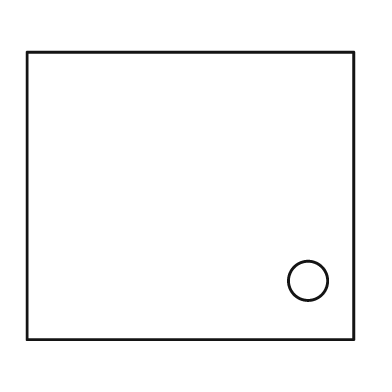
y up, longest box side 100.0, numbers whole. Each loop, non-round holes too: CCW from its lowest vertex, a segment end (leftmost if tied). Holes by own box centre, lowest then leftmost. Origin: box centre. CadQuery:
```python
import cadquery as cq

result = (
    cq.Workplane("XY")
    .moveTo(-50.0, -44.0)
    .lineTo(50.0, -44.0)
    .lineTo(50.0, 44.0)
    .lineTo(-50.0, 44.0)
    .close()
    .moveTo(36.0, -26.0)
    .circle(6.0)
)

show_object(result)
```